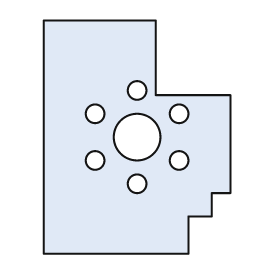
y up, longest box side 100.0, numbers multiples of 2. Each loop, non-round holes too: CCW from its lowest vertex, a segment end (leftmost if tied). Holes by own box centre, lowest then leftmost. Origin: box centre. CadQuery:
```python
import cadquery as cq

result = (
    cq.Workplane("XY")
    .moveTo(-40.0, -50.0)
    .lineTo(22.0, -50.0)
    .lineTo(22.0, -34.0)
    .lineTo(32.0, -34.0)
    .lineTo(32.0, -24.0)
    .lineTo(40.0, -24.0)
    .lineTo(40.0, 18.0)
    .lineTo(8.0, 18.0)
    .lineTo(8.0, 50.0)
    .lineTo(-40.0, 50.0)
    .close()
    .moveTo(0.0, -20.0)
    .circle(4.0)
    .moveTo(-18.0, -10.0)
    .circle(4.0)
    .moveTo(18.0, -10.0)
    .circle(4.0)
    .moveTo(0.0, 0.0)
    .circle(10.0)
    .moveTo(-18.0, 10.0)
    .circle(4.0)
    .moveTo(18.0, 10.0)
    .circle(4.0)
    .moveTo(0.0, 20.0)
    .circle(4.0)
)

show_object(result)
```